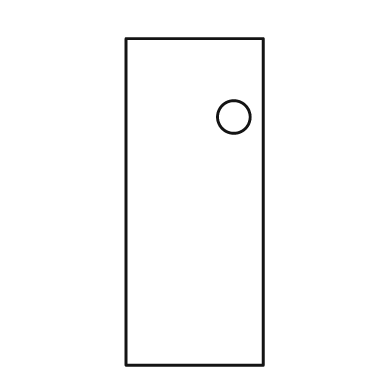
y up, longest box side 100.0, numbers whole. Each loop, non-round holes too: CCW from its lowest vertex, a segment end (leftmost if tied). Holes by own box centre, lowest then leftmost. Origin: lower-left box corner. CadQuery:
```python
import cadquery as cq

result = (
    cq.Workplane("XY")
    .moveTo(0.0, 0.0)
    .lineTo(42.0, 0.0)
    .lineTo(42.0, 100.0)
    .lineTo(0.0, 100.0)
    .close()
    .moveTo(33.0, 76.0)
    .circle(5.0)
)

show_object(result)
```